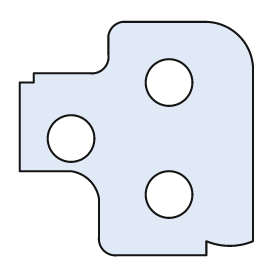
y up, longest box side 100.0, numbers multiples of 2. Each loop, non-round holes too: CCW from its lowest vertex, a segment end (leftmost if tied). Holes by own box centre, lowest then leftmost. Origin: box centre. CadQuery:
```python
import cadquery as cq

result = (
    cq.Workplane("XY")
    .moveTo(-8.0, -50.0)
    .lineTo(30.0, -50.0)
    .lineTo(30.0, -44.0)
    .threePointArc((40.0, -46.0), (50.0, -44.0))
    .lineTo(50.0, 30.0)
    .threePointArc((44.0, 44.0), (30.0, 50.0))
    .lineTo(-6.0, 50.0)
    .threePointArc((-10.0, 48.0), (-12.0, 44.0))
    .lineTo(-12.0, 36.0)
    .threePointArc((-14.0, 30.0), (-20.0, 28.0))
    .lineTo(-44.0, 28.0)
    .lineTo(-44.0, 24.0)
    .lineTo(-50.0, 24.0)
    .lineTo(-50.0, -14.0)
    .lineTo(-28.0, -14.0)
    .threePointArc((-20.0, -18.0), (-16.0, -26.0))
    .lineTo(-16.0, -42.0)
    .threePointArc((-14.0, -48.0), (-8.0, -50.0))
    .close()
    .moveTo(14.0, -24.0)
    .circle(10.0)
    .moveTo(-28.0, 0.0)
    .circle(10.0)
    .moveTo(14.0, 24.0)
    .circle(10.0)
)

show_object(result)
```